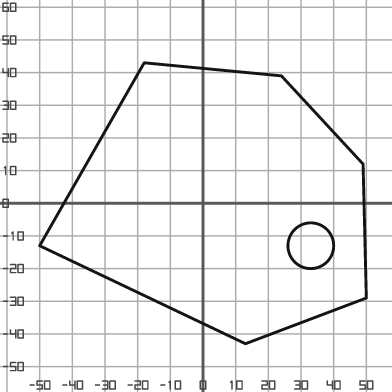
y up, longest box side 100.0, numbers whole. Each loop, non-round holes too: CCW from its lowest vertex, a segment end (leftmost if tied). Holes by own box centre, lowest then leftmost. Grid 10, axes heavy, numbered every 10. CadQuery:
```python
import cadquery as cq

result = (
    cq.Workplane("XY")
    .moveTo(13.0, -43.0)
    .lineTo(50.0, -29.0)
    .lineTo(49.0, 12.0)
    .lineTo(24.0, 39.0)
    .lineTo(-18.0, 43.0)
    .lineTo(-50.0, -13.0)
    .close()
    .moveTo(33.0, -13.0)
    .circle(7.0)
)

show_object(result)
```